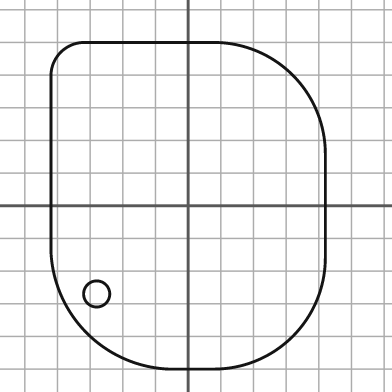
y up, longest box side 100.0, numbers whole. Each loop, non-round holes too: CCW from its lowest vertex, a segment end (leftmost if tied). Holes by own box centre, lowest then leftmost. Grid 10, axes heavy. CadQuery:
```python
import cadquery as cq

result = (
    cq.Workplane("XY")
    .moveTo(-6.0, -50.0)
    .lineTo(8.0, -50.0)
    .threePointArc((32.0, -40.0), (42.0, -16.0))
    .lineTo(42.0, 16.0)
    .threePointArc((32.0, 40.0), (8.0, 50.0))
    .lineTo(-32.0, 50.0)
    .threePointArc((-39.0, 47.0), (-42.0, 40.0))
    .lineTo(-42.0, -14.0)
    .threePointArc((-31.0, -39.0), (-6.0, -50.0))
    .close()
    .moveTo(-28.0, -27.0)
    .circle(4.0)
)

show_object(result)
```